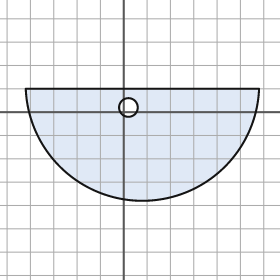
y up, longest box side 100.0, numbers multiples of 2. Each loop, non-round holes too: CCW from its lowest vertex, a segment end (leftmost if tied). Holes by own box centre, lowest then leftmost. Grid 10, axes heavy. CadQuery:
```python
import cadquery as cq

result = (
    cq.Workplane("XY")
    .moveTo(-42.0, 10.0)
    .threePointArc((8.0, -38.0), (58.0, 10.0))
    .close()
    .moveTo(2.0, 2.0)
    .circle(4.0)
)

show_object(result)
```